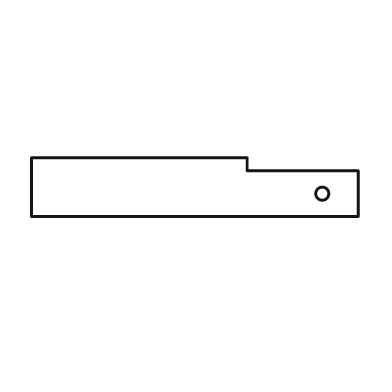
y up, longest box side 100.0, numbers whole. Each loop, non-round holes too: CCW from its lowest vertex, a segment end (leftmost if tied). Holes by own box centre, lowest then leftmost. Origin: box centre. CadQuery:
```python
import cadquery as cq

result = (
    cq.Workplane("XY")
    .moveTo(-50.0, -9.0)
    .lineTo(50.0, -9.0)
    .lineTo(50.0, 5.0)
    .lineTo(16.0, 5.0)
    .lineTo(16.0, 9.0)
    .lineTo(-50.0, 9.0)
    .close()
    .moveTo(39.0, -2.0)
    .circle(2.0)
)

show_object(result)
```